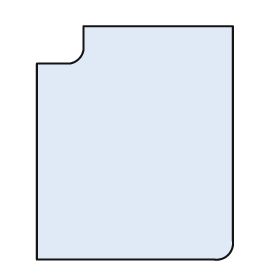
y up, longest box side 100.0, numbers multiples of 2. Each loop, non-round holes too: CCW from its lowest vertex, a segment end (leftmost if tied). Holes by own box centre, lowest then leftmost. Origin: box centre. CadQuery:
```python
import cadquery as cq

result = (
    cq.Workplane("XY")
    .moveTo(-42.0, -50.0)
    .lineTo(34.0, -50.0)
    .threePointArc((40.0, -48.0), (42.0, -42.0))
    .lineTo(42.0, 50.0)
    .lineTo(-22.0, 50.0)
    .lineTo(-22.0, 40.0)
    .threePointArc((-24.0, 36.0), (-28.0, 34.0))
    .lineTo(-42.0, 34.0)
    .close()
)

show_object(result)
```